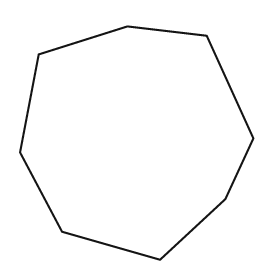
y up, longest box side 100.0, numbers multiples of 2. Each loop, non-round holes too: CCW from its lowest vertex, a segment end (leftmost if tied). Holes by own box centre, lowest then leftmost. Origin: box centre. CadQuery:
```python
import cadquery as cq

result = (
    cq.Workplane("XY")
    .moveTo(10.0, -50.0)
    .lineTo(38.0, -24.0)
    .lineTo(50.0, 2.0)
    .lineTo(30.0, 46.0)
    .lineTo(-4.0, 50.0)
    .lineTo(-42.0, 38.0)
    .lineTo(-50.0, -4.0)
    .lineTo(-32.0, -38.0)
    .close()
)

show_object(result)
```